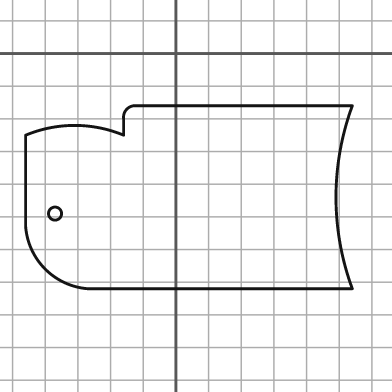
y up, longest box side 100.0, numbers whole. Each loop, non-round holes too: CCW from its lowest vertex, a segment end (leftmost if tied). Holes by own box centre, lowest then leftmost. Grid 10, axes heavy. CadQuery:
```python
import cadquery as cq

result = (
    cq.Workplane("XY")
    .moveTo(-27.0, -72.0)
    .lineTo(54.0, -72.0)
    .threePointArc((49.0, -44.0), (54.0, -16.0))
    .lineTo(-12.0, -16.0)
    .threePointArc((-15.0, -17.0), (-16.0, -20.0))
    .lineTo(-16.0, -25.0)
    .threePointArc((-31.0, -22.0), (-46.0, -25.0))
    .lineTo(-46.0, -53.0)
    .threePointArc((-40.0, -66.0), (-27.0, -72.0))
    .close()
    .moveTo(-37.0, -49.0)
    .circle(2.0)
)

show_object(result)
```